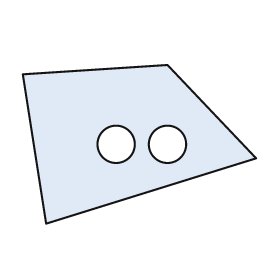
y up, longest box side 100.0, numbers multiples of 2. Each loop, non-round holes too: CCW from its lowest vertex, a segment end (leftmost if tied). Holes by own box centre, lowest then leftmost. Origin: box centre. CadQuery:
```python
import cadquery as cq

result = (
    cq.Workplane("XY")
    .moveTo(-40.0, -34.0)
    .lineTo(50.0, -6.0)
    .lineTo(12.0, 34.0)
    .lineTo(-50.0, 30.0)
    .close()
    .moveTo(-10.0, 0.0)
    .circle(8.0)
    .moveTo(12.0, 0.0)
    .circle(8.0)
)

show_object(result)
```